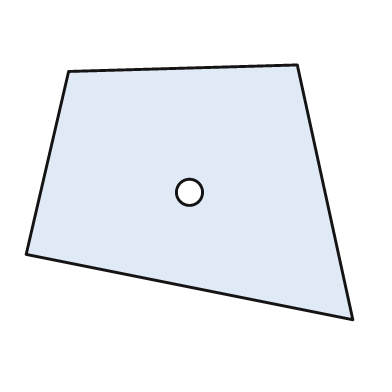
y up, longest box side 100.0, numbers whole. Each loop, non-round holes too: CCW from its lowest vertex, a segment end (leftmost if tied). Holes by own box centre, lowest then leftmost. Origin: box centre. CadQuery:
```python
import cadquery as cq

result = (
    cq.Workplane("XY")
    .moveTo(50.0, -39.0)
    .lineTo(33.0, 39.0)
    .lineTo(-37.0, 37.0)
    .lineTo(-50.0, -19.0)
    .close()
    .moveTo(0.0, 0.0)
    .circle(4.0)
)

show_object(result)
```